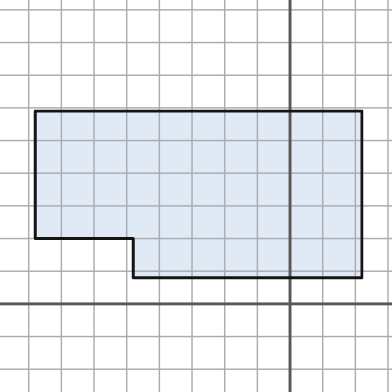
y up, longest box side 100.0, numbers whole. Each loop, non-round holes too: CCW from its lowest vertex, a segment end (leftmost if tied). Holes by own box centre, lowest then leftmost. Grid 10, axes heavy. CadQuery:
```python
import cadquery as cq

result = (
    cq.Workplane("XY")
    .moveTo(-48.0, 8.0)
    .lineTo(22.0, 8.0)
    .lineTo(22.0, 59.0)
    .lineTo(-78.0, 59.0)
    .lineTo(-78.0, 20.0)
    .lineTo(-48.0, 20.0)
    .close()
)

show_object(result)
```